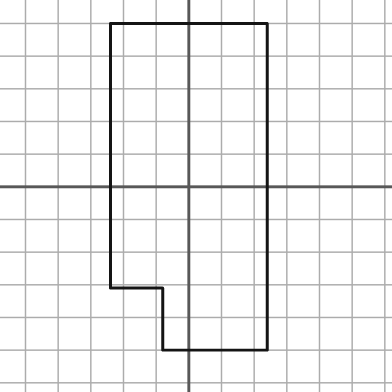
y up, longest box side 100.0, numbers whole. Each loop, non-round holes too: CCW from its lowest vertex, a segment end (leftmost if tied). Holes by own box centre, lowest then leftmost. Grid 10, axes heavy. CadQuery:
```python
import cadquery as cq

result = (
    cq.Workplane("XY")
    .moveTo(-8.0, -50.0)
    .lineTo(24.0, -50.0)
    .lineTo(24.0, 50.0)
    .lineTo(-24.0, 50.0)
    .lineTo(-24.0, -31.0)
    .lineTo(-8.0, -31.0)
    .close()
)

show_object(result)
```